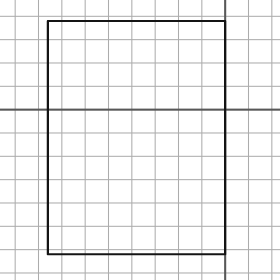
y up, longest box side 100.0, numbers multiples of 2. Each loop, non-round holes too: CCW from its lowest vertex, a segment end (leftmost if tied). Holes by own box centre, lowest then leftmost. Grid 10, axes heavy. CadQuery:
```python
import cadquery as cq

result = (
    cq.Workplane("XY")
    .moveTo(-76.0, -62.0)
    .lineTo(0.0, -62.0)
    .lineTo(0.0, 38.0)
    .lineTo(-76.0, 38.0)
    .close()
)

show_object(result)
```